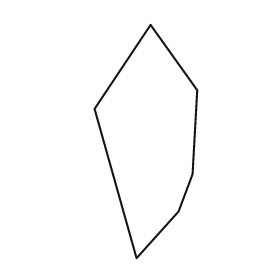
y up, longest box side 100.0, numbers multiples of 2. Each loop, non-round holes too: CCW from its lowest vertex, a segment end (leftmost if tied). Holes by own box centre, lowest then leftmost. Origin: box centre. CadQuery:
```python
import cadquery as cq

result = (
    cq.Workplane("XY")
    .moveTo(-4.0, -50.0)
    .lineTo(14.0, -30.0)
    .lineTo(20.0, -14.0)
    .lineTo(22.0, 22.0)
    .lineTo(2.0, 50.0)
    .lineTo(-22.0, 14.0)
    .close()
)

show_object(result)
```